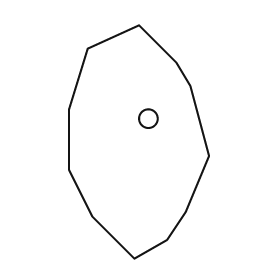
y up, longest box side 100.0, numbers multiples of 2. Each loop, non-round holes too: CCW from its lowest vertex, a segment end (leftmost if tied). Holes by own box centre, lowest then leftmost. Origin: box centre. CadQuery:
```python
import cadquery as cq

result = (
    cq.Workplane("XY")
    .moveTo(-2.0, -50.0)
    .lineTo(12.0, -42.0)
    .lineTo(20.0, -30.0)
    .lineTo(30.0, -6.0)
    .lineTo(22.0, 24.0)
    .lineTo(16.0, 34.0)
    .lineTo(0.0, 50.0)
    .lineTo(-22.0, 40.0)
    .lineTo(-30.0, 14.0)
    .lineTo(-30.0, -12.0)
    .lineTo(-20.0, -32.0)
    .close()
    .moveTo(4.0, 10.0)
    .circle(4.0)
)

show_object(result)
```